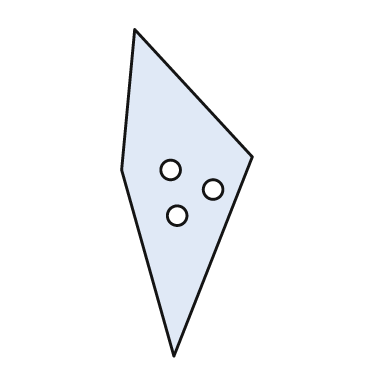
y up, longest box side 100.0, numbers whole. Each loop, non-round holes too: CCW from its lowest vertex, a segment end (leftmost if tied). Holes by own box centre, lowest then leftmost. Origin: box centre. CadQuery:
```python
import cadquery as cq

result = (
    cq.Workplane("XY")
    .moveTo(-4.0, -50.0)
    .lineTo(20.0, 11.0)
    .lineTo(-16.0, 50.0)
    .lineTo(-20.0, 7.0)
    .close()
    .moveTo(-3.0, -7.0)
    .circle(3.0)
    .moveTo(8.0, 1.0)
    .circle(3.0)
    .moveTo(-5.0, 7.0)
    .circle(3.0)
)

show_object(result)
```